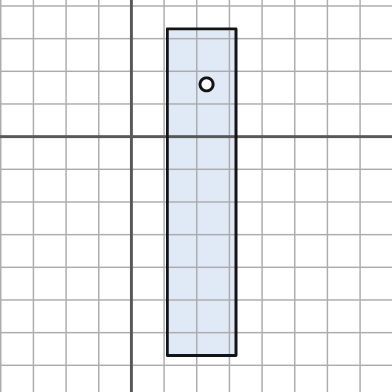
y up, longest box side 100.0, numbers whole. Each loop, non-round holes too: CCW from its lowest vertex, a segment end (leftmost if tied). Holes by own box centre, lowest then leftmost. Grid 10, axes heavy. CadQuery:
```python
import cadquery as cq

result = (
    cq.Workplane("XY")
    .moveTo(11.0, -67.0)
    .lineTo(32.0, -67.0)
    .lineTo(32.0, 33.0)
    .lineTo(11.0, 33.0)
    .close()
    .moveTo(23.0, 16.0)
    .circle(2.0)
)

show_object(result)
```